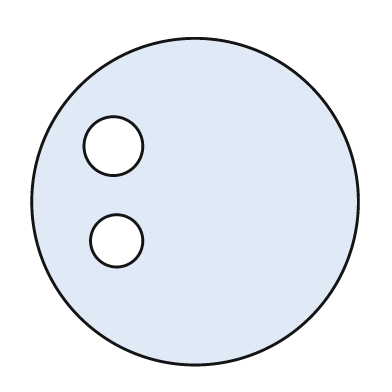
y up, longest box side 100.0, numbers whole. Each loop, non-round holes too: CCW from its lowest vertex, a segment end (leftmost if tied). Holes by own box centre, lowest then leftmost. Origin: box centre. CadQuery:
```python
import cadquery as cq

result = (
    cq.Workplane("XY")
    .moveTo(0.0, 0.0)
    .circle(50.0)
    .moveTo(-24.0, -12.0)
    .circle(8.0)
    .moveTo(-25.0, 17.0)
    .circle(9.0)
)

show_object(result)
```